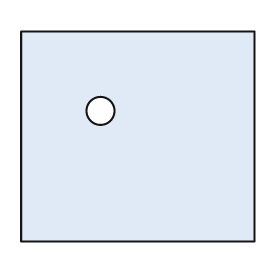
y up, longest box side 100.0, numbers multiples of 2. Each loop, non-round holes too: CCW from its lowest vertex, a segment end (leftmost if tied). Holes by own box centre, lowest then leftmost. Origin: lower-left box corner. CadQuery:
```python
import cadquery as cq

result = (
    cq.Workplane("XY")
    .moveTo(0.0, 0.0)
    .lineTo(100.0, 0.0)
    .lineTo(100.0, 90.0)
    .lineTo(0.0, 90.0)
    .close()
    .moveTo(34.0, 56.0)
    .circle(6.0)
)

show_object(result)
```